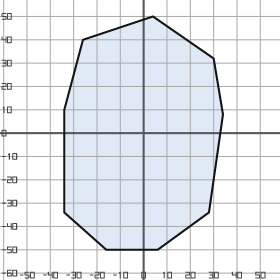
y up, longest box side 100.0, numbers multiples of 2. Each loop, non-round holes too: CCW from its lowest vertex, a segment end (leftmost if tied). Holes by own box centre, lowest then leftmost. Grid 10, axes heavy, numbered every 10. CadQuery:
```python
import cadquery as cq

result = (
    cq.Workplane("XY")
    .moveTo(-16.0, -50.0)
    .lineTo(6.0, -50.0)
    .lineTo(28.0, -34.0)
    .lineTo(34.0, 8.0)
    .lineTo(30.0, 32.0)
    .lineTo(4.0, 50.0)
    .lineTo(-26.0, 40.0)
    .lineTo(-34.0, 10.0)
    .lineTo(-34.0, -34.0)
    .close()
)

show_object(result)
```